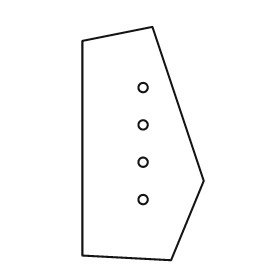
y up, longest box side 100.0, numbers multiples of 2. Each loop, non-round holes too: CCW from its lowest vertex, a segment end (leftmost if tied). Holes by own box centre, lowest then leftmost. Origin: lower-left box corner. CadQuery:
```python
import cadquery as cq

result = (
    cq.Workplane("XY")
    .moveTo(38.0, 0.0)
    .lineTo(52.0, 34.0)
    .lineTo(30.0, 100.0)
    .lineTo(0.0, 94.0)
    .lineTo(0.0, 2.0)
    .close()
    .moveTo(26.0, 26.0)
    .circle(2.0)
    .moveTo(26.0, 42.0)
    .circle(2.0)
    .moveTo(26.0, 58.0)
    .circle(2.0)
    .moveTo(26.0, 74.0)
    .circle(2.0)
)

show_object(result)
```